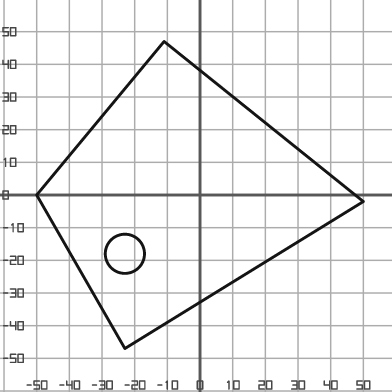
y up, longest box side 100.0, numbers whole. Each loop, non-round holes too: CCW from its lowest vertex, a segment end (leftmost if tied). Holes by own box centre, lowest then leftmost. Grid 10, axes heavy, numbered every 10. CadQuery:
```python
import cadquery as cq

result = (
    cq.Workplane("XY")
    .moveTo(-23.0, -47.0)
    .lineTo(50.0, -2.0)
    .lineTo(-11.0, 47.0)
    .lineTo(-50.0, 0.0)
    .close()
    .moveTo(-23.0, -18.0)
    .circle(6.0)
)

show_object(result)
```